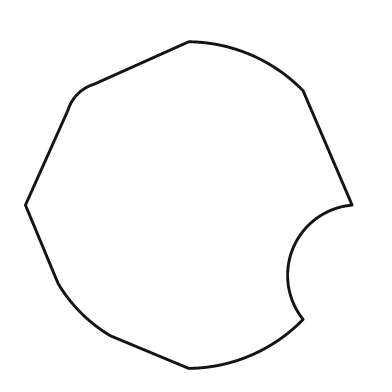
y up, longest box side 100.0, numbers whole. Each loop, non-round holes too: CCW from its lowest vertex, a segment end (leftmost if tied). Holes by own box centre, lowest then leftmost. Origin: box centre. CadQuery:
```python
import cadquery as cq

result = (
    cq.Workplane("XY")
    .moveTo(0.0, -50.0)
    .threePointArc((19.0, -46.0), (35.0, -35.0))
    .threePointArc((32.0, -13.0), (50.0, 0.0))
    .lineTo(35.0, 35.0)
    .threePointArc((19.0, 46.0), (0.0, 50.0))
    .lineTo(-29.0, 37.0)
    .threePointArc((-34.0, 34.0), (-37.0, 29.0))
    .lineTo(-50.0, 0.0)
    .lineTo(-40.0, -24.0)
    .threePointArc((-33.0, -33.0), (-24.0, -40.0))
    .close()
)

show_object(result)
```